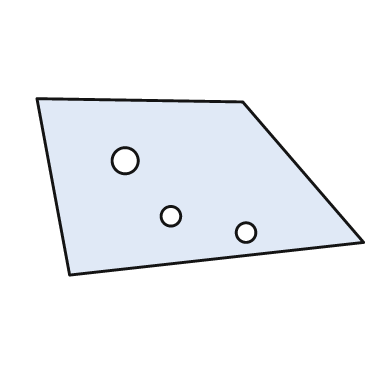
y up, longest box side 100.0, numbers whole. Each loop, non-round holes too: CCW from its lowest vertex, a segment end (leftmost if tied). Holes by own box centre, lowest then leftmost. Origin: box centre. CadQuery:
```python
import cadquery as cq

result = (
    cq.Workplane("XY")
    .moveTo(-40.0, -27.0)
    .lineTo(50.0, -17.0)
    .lineTo(13.0, 26.0)
    .lineTo(-50.0, 27.0)
    .close()
    .moveTo(14.0, -14.0)
    .circle(3.0)
    .moveTo(-9.0, -9.0)
    .circle(3.0)
    .moveTo(-23.0, 8.0)
    .circle(4.0)
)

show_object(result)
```